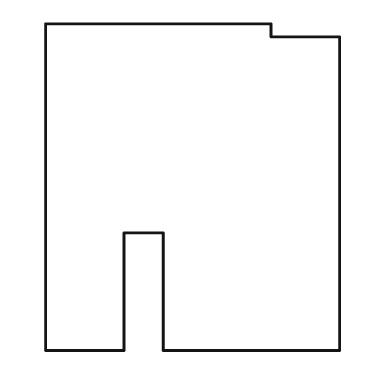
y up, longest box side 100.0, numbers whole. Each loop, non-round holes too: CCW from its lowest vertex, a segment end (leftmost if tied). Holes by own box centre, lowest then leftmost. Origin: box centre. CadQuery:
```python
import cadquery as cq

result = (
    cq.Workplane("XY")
    .moveTo(-45.0, -50.0)
    .lineTo(-21.0, -50.0)
    .lineTo(-21.0, -14.0)
    .lineTo(-9.0, -14.0)
    .lineTo(-9.0, -50.0)
    .lineTo(45.0, -50.0)
    .lineTo(45.0, 46.0)
    .lineTo(24.0, 46.0)
    .lineTo(24.0, 50.0)
    .lineTo(-45.0, 50.0)
    .close()
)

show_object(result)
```